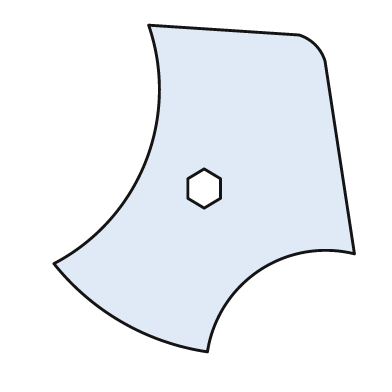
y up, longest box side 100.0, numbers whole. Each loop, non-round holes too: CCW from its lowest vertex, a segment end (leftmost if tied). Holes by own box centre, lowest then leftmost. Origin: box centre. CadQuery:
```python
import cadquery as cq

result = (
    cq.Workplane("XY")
    .moveTo(1.0, -50.0)
    .threePointArc((17.0, -25.0), (46.0, -20.0))
    .lineTo(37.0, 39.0)
    .threePointArc((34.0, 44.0), (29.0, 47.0))
    .lineTo(-17.0, 50.0)
    .threePointArc((-18.0, 8.0), (-46.0, -23.0))
    .threePointArc((-25.0, -41.0), (1.0, -50.0))
    .close()
    .moveTo(0.0, -6.0)
    .lineTo(5.0, -3.0)
    .lineTo(5.0, 3.0)
    .lineTo(0.0, 6.0)
    .lineTo(-5.0, 3.0)
    .lineTo(-5.0, -3.0)
    .close()
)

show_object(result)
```